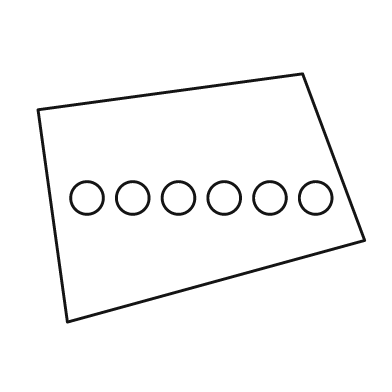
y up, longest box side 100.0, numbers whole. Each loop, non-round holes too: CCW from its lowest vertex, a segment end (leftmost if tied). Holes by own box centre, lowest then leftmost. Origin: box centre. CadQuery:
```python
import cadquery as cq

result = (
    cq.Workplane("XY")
    .moveTo(-41.0, -38.0)
    .lineTo(50.0, -13.0)
    .lineTo(31.0, 38.0)
    .lineTo(-50.0, 27.0)
    .close()
    .moveTo(-35.0, 0.0)
    .circle(5.0)
    .moveTo(-21.0, 0.0)
    .circle(5.0)
    .moveTo(-7.0, 0.0)
    .circle(5.0)
    .moveTo(7.0, 0.0)
    .circle(5.0)
    .moveTo(21.0, 0.0)
    .circle(5.0)
    .moveTo(35.0, 0.0)
    .circle(5.0)
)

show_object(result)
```